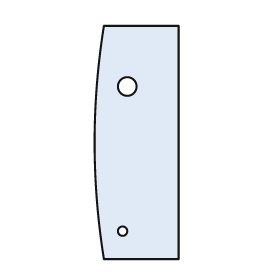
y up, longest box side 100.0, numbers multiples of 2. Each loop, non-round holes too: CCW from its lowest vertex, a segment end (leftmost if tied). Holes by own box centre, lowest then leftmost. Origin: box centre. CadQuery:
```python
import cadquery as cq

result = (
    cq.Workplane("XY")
    .moveTo(-14.0, -50.0)
    .lineTo(18.0, -50.0)
    .lineTo(18.0, 50.0)
    .lineTo(-14.0, 50.0)
    .threePointArc((-18.0, 0.0), (-14.0, -50.0))
    .close()
    .moveTo(-6.0, -38.0)
    .circle(2.0)
    .moveTo(-4.0, 24.0)
    .circle(4.0)
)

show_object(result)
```